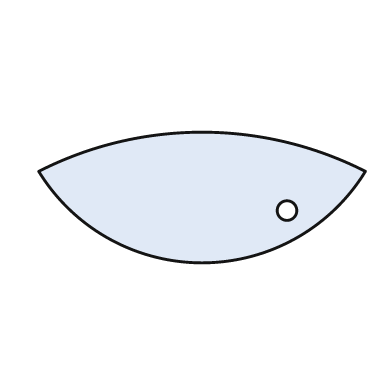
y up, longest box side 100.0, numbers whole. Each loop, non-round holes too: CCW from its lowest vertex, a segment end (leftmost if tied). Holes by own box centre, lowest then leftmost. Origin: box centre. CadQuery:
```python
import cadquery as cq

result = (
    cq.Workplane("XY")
    .moveTo(-50.0, 8.0)
    .threePointArc((0.0, -20.0), (50.0, 8.0))
    .threePointArc((0.0, 20.0), (-50.0, 8.0))
    .close()
    .moveTo(26.0, -4.0)
    .circle(3.0)
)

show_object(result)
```